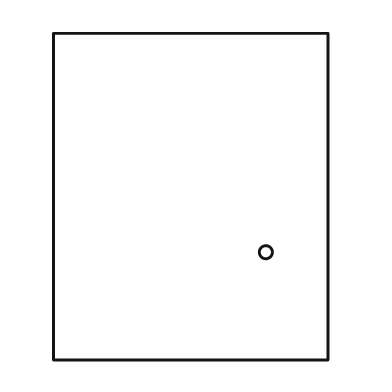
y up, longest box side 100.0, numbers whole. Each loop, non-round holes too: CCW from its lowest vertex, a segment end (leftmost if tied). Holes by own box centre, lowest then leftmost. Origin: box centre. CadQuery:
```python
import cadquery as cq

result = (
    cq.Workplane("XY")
    .moveTo(-42.0, -50.0)
    .lineTo(42.0, -50.0)
    .lineTo(42.0, 50.0)
    .lineTo(-42.0, 50.0)
    .close()
    .moveTo(23.0, -17.0)
    .circle(2.0)
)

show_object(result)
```